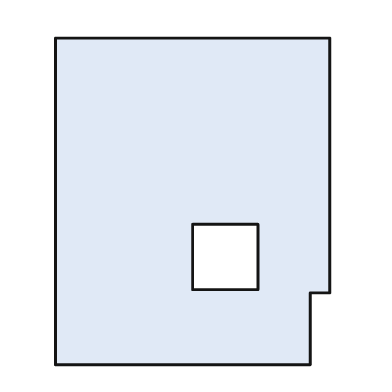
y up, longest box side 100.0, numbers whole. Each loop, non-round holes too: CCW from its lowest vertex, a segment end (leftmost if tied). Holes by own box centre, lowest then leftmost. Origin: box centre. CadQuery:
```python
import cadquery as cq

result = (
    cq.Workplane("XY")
    .moveTo(-42.0, -50.0)
    .lineTo(36.0, -50.0)
    .lineTo(36.0, -28.0)
    .lineTo(42.0, -28.0)
    .lineTo(42.0, 50.0)
    .lineTo(-42.0, 50.0)
    .close()
    .moveTo(0.0, -27.0)
    .lineTo(20.0, -27.0)
    .lineTo(20.0, -7.0)
    .lineTo(0.0, -7.0)
    .close()
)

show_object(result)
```